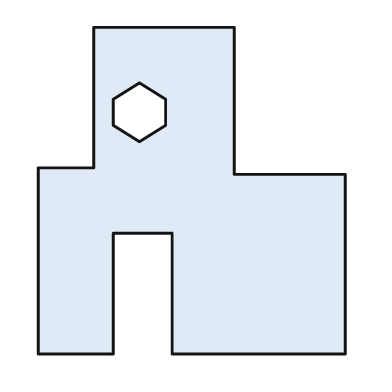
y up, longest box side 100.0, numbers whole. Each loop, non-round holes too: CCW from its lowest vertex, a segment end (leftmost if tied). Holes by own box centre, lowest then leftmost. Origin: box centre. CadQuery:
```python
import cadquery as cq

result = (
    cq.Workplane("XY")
    .moveTo(-47.0, -50.0)
    .lineTo(-24.0, -50.0)
    .lineTo(-24.0, -13.0)
    .lineTo(-6.0, -13.0)
    .lineTo(-6.0, -50.0)
    .lineTo(47.0, -50.0)
    .lineTo(47.0, 5.0)
    .lineTo(13.0, 5.0)
    .lineTo(13.0, 50.0)
    .lineTo(-30.0, 50.0)
    .lineTo(-30.0, 7.0)
    .lineTo(-47.0, 7.0)
    .close()
    .moveTo(-16.0, 15.0)
    .lineTo(-8.0, 20.0)
    .lineTo(-8.0, 28.0)
    .lineTo(-16.0, 33.0)
    .lineTo(-24.0, 28.0)
    .lineTo(-24.0, 20.0)
    .close()
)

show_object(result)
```